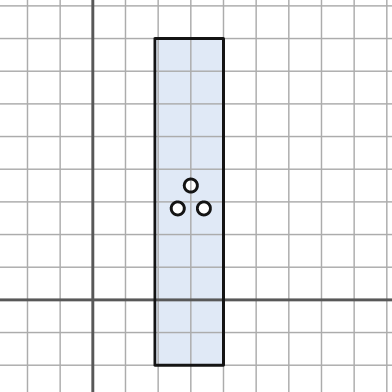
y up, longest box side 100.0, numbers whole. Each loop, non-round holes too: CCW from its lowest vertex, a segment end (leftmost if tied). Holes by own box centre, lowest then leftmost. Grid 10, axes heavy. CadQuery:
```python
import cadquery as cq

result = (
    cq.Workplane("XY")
    .moveTo(19.0, -20.0)
    .lineTo(40.0, -20.0)
    .lineTo(40.0, 80.0)
    .lineTo(19.0, 80.0)
    .close()
    .moveTo(26.0, 28.0)
    .circle(2.0)
    .moveTo(34.0, 28.0)
    .circle(2.0)
    .moveTo(30.0, 35.0)
    .circle(2.0)
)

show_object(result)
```